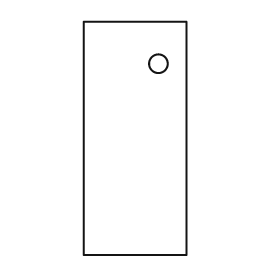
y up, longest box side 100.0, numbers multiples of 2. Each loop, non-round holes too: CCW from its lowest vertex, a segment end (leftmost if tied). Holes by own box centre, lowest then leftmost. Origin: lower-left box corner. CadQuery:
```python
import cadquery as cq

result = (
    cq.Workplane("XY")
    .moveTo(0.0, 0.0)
    .lineTo(44.0, 0.0)
    .lineTo(44.0, 100.0)
    .lineTo(0.0, 100.0)
    .close()
    .moveTo(32.0, 82.0)
    .circle(4.0)
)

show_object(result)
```